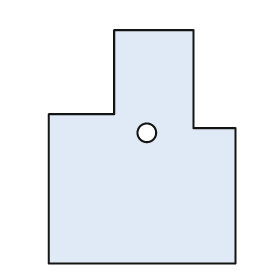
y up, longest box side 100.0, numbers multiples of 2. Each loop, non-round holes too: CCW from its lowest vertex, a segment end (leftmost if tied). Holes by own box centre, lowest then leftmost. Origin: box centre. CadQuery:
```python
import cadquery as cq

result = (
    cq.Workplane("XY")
    .moveTo(-40.0, -50.0)
    .lineTo(40.0, -50.0)
    .lineTo(40.0, 8.0)
    .lineTo(22.0, 8.0)
    .lineTo(22.0, 50.0)
    .lineTo(-12.0, 50.0)
    .lineTo(-12.0, 14.0)
    .lineTo(-40.0, 14.0)
    .close()
    .moveTo(2.0, 6.0)
    .circle(4.0)
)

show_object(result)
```